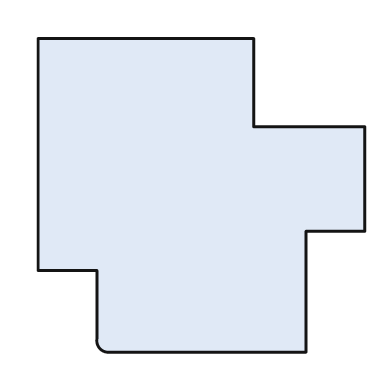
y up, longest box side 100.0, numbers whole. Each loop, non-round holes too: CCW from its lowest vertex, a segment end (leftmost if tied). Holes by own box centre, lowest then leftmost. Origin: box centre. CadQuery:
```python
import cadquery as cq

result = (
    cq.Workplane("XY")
    .moveTo(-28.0, -48.0)
    .lineTo(32.0, -48.0)
    .lineTo(32.0, -11.0)
    .lineTo(50.0, -11.0)
    .lineTo(50.0, 21.0)
    .lineTo(16.0, 21.0)
    .lineTo(16.0, 48.0)
    .lineTo(-50.0, 48.0)
    .lineTo(-50.0, -23.0)
    .lineTo(-32.0, -23.0)
    .lineTo(-32.0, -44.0)
    .threePointArc((-31.0, -47.0), (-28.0, -48.0))
    .close()
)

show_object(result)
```